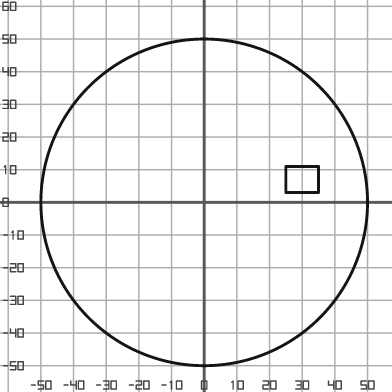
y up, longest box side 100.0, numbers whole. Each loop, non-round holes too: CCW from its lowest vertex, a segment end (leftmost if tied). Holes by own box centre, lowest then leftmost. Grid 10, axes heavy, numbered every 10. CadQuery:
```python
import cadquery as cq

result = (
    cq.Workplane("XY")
    .moveTo(0.0, 0.0)
    .circle(50.0)
    .moveTo(25.0, 3.0)
    .lineTo(35.0, 3.0)
    .lineTo(35.0, 11.0)
    .lineTo(25.0, 11.0)
    .close()
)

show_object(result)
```